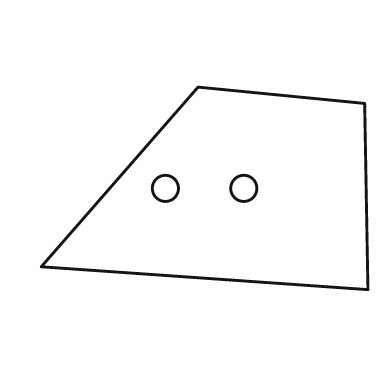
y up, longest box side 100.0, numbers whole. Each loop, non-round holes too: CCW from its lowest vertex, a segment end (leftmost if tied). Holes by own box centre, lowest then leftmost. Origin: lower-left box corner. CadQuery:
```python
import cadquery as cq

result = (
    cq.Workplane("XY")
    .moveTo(100.0, 0.0)
    .lineTo(99.0, 57.0)
    .lineTo(48.0, 62.0)
    .lineTo(0.0, 7.0)
    .close()
    .moveTo(38.0, 31.0)
    .circle(4.0)
    .moveTo(62.0, 31.0)
    .circle(4.0)
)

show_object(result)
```